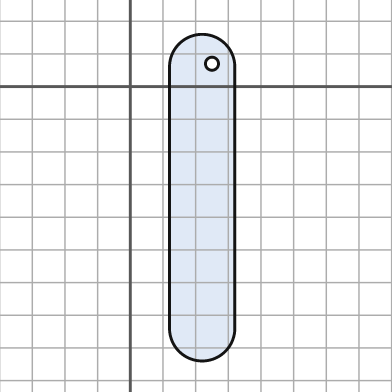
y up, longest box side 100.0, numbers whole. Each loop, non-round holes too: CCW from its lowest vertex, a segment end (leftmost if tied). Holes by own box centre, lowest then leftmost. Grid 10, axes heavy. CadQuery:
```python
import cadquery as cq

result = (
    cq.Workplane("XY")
    .moveTo(12.0, -74.0)
    .threePointArc((22.0, -84.0), (32.0, -74.0))
    .lineTo(32.0, 6.0)
    .threePointArc((22.0, 16.0), (12.0, 6.0))
    .close()
    .moveTo(25.0, 7.0)
    .circle(2.0)
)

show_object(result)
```